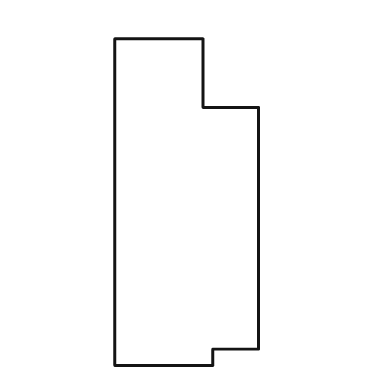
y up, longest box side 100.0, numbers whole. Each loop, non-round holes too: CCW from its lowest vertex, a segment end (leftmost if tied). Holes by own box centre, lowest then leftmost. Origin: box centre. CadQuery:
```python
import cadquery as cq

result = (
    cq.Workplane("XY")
    .moveTo(-22.0, -50.0)
    .lineTo(8.0, -50.0)
    .lineTo(8.0, -45.0)
    .lineTo(22.0, -45.0)
    .lineTo(22.0, 29.0)
    .lineTo(5.0, 29.0)
    .lineTo(5.0, 50.0)
    .lineTo(-22.0, 50.0)
    .close()
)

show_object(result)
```